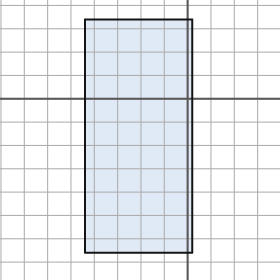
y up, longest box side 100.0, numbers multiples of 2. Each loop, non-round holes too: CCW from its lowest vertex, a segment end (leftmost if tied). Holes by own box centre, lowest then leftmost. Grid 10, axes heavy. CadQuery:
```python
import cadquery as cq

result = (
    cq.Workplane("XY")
    .moveTo(-44.0, -66.0)
    .lineTo(2.0, -66.0)
    .lineTo(2.0, 34.0)
    .lineTo(-44.0, 34.0)
    .close()
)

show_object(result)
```